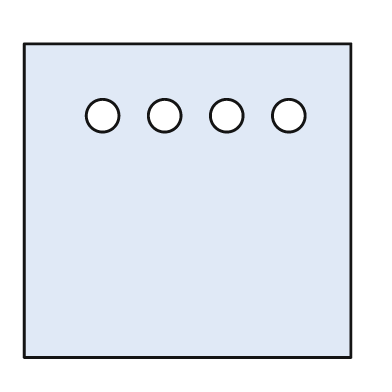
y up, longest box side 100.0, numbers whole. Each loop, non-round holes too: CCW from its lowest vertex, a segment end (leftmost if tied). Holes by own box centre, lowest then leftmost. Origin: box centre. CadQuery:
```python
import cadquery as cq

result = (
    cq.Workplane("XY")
    .moveTo(-50.0, -48.0)
    .lineTo(50.0, -48.0)
    .lineTo(50.0, 48.0)
    .lineTo(-50.0, 48.0)
    .close()
    .moveTo(-26.0, 26.0)
    .circle(5.0)
    .moveTo(-7.0, 26.0)
    .circle(5.0)
    .moveTo(12.0, 26.0)
    .circle(5.0)
    .moveTo(31.0, 26.0)
    .circle(5.0)
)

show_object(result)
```